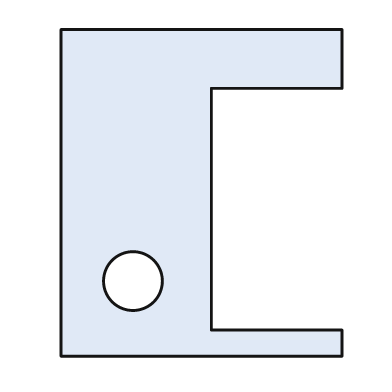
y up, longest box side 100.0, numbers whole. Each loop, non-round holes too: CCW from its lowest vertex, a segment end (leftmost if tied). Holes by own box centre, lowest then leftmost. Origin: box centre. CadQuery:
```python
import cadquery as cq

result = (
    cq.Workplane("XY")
    .moveTo(-43.0, -50.0)
    .lineTo(43.0, -50.0)
    .lineTo(43.0, -42.0)
    .lineTo(3.0, -42.0)
    .lineTo(3.0, 32.0)
    .lineTo(43.0, 32.0)
    .lineTo(43.0, 50.0)
    .lineTo(-43.0, 50.0)
    .close()
    .moveTo(-21.0, -27.0)
    .circle(9.0)
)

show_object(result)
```